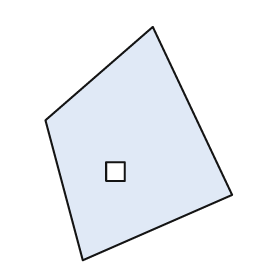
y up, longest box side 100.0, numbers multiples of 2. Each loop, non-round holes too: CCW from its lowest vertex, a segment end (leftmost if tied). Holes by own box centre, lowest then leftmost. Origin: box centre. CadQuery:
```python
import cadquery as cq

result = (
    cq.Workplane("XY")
    .moveTo(-24.0, -50.0)
    .lineTo(40.0, -22.0)
    .lineTo(6.0, 50.0)
    .lineTo(-40.0, 10.0)
    .close()
    .moveTo(-14.0, -16.0)
    .lineTo(-6.0, -16.0)
    .lineTo(-6.0, -8.0)
    .lineTo(-14.0, -8.0)
    .close()
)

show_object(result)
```